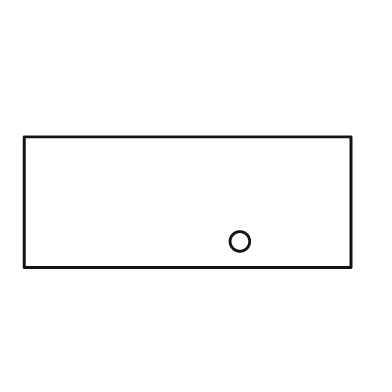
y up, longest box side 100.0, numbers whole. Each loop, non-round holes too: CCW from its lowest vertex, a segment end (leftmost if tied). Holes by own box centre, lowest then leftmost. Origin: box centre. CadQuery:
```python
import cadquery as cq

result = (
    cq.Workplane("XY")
    .moveTo(-50.0, -20.0)
    .lineTo(50.0, -20.0)
    .lineTo(50.0, 20.0)
    .lineTo(-50.0, 20.0)
    .close()
    .moveTo(16.0, -12.0)
    .circle(3.0)
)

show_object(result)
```